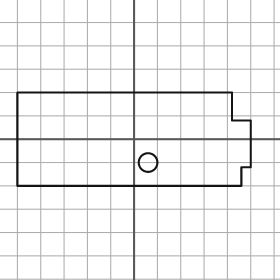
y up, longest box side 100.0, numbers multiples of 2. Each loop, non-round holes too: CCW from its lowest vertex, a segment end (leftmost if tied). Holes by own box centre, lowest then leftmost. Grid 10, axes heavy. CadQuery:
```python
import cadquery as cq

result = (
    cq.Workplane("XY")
    .moveTo(-50.0, -20.0)
    .lineTo(46.0, -20.0)
    .lineTo(46.0, -12.0)
    .lineTo(50.0, -12.0)
    .lineTo(50.0, 8.0)
    .lineTo(42.0, 8.0)
    .lineTo(42.0, 20.0)
    .lineTo(-50.0, 20.0)
    .close()
    .moveTo(6.0, -10.0)
    .circle(4.0)
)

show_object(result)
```